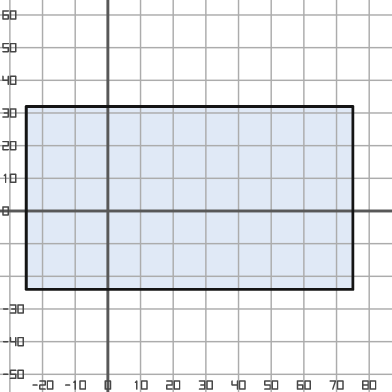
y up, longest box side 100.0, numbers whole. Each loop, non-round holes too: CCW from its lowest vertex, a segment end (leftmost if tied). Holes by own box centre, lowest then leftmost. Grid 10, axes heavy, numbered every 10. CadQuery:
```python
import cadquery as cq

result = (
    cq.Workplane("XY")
    .moveTo(-25.0, -24.0)
    .lineTo(75.0, -24.0)
    .lineTo(75.0, 32.0)
    .lineTo(-25.0, 32.0)
    .close()
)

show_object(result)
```